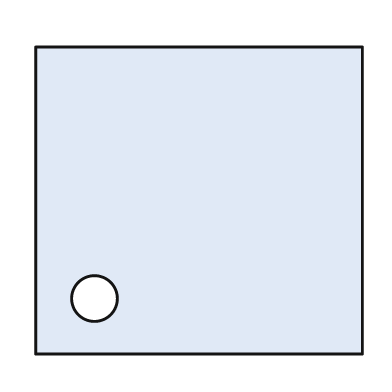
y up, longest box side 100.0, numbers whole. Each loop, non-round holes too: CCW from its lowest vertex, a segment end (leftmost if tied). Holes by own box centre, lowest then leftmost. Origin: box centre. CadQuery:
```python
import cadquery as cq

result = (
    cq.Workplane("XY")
    .moveTo(-50.0, -47.0)
    .lineTo(50.0, -47.0)
    .lineTo(50.0, 47.0)
    .lineTo(-50.0, 47.0)
    .close()
    .moveTo(-32.0, -30.0)
    .circle(7.0)
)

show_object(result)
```